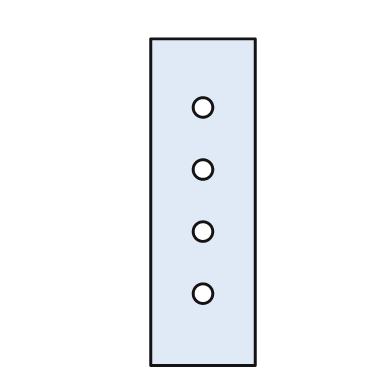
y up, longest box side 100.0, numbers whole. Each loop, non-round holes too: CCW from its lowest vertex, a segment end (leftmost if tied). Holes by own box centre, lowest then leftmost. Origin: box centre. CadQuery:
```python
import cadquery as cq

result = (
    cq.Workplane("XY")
    .moveTo(-16.0, -50.0)
    .lineTo(16.0, -50.0)
    .lineTo(16.0, 50.0)
    .lineTo(-16.0, 50.0)
    .close()
    .moveTo(0.0, -28.0)
    .circle(3.0)
    .moveTo(0.0, -9.0)
    .circle(3.0)
    .moveTo(0.0, 10.0)
    .circle(3.0)
    .moveTo(0.0, 29.0)
    .circle(3.0)
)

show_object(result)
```